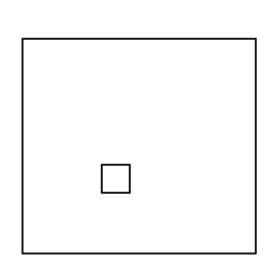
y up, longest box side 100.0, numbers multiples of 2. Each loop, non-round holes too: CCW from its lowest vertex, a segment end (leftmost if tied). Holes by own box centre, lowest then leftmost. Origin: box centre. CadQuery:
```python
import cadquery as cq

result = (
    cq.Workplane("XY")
    .moveTo(-50.0, -46.0)
    .lineTo(50.0, -46.0)
    .lineTo(50.0, 46.0)
    .lineTo(-50.0, 46.0)
    .close()
    .moveTo(-16.0, -20.0)
    .lineTo(-4.0, -20.0)
    .lineTo(-4.0, -8.0)
    .lineTo(-16.0, -8.0)
    .close()
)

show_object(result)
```